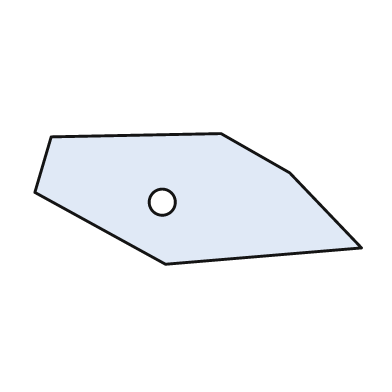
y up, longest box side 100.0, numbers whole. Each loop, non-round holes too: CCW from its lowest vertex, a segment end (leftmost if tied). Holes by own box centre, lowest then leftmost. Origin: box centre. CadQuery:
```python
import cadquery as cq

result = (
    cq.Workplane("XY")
    .moveTo(-10.0, -20.0)
    .lineTo(50.0, -15.0)
    .lineTo(28.0, 8.0)
    .lineTo(7.0, 20.0)
    .lineTo(-45.0, 19.0)
    .lineTo(-50.0, 2.0)
    .close()
    .moveTo(-11.0, -1.0)
    .circle(4.0)
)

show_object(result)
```